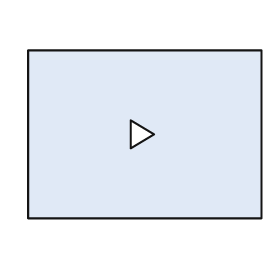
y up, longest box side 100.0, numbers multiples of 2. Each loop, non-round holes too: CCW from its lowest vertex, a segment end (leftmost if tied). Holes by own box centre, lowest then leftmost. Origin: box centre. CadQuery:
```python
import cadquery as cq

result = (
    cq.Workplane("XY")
    .moveTo(-50.0, -36.0)
    .lineTo(50.0, -36.0)
    .lineTo(50.0, 36.0)
    .lineTo(-50.0, 36.0)
    .close()
    .moveTo(-6.0, -6.0)
    .lineTo(4.0, 0.0)
    .lineTo(-6.0, 6.0)
    .close()
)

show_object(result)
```